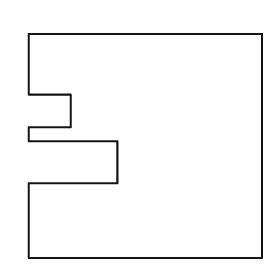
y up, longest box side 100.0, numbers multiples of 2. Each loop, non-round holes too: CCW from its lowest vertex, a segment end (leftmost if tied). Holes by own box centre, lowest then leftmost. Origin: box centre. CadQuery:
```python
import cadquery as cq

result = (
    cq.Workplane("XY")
    .moveTo(-50.0, -48.0)
    .lineTo(50.0, -48.0)
    .lineTo(50.0, 48.0)
    .lineTo(-50.0, 48.0)
    .lineTo(-50.0, 22.0)
    .lineTo(-32.0, 22.0)
    .lineTo(-32.0, 8.0)
    .lineTo(-50.0, 8.0)
    .lineTo(-50.0, 2.0)
    .lineTo(-12.0, 2.0)
    .lineTo(-12.0, -16.0)
    .lineTo(-50.0, -16.0)
    .close()
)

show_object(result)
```